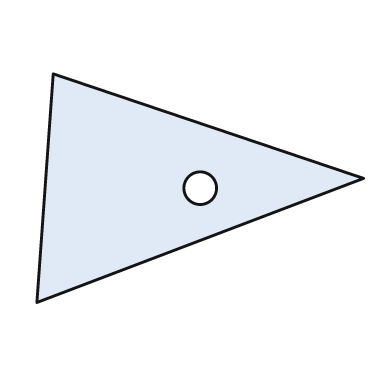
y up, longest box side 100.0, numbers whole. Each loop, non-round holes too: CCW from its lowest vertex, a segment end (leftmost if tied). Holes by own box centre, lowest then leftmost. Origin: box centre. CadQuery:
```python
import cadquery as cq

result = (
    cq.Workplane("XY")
    .moveTo(-50.0, -35.0)
    .lineTo(50.0, 3.0)
    .lineTo(-45.0, 35.0)
    .close()
    .moveTo(0.0, 0.0)
    .circle(5.0)
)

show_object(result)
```